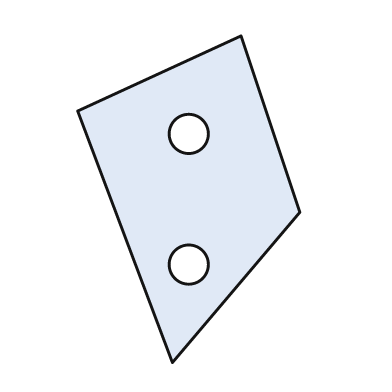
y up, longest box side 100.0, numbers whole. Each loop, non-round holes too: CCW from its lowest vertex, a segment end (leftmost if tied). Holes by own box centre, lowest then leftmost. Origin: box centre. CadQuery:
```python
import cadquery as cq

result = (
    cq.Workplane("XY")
    .moveTo(-5.0, -50.0)
    .lineTo(34.0, -4.0)
    .lineTo(16.0, 50.0)
    .lineTo(-34.0, 27.0)
    .close()
    .moveTo(0.0, -20.0)
    .circle(6.0)
    .moveTo(0.0, 20.0)
    .circle(6.0)
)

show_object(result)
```